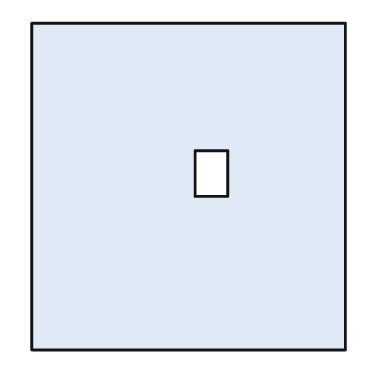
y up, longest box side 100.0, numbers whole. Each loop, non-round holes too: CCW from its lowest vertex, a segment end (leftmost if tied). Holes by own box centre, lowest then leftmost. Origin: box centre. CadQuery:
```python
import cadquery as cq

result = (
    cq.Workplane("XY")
    .moveTo(-48.0, -50.0)
    .lineTo(48.0, -50.0)
    .lineTo(48.0, 50.0)
    .lineTo(-48.0, 50.0)
    .close()
    .moveTo(2.0, -3.0)
    .lineTo(12.0, -3.0)
    .lineTo(12.0, 11.0)
    .lineTo(2.0, 11.0)
    .close()
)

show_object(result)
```